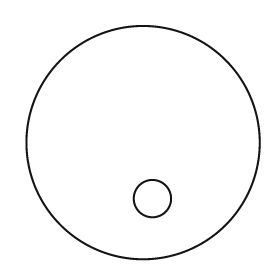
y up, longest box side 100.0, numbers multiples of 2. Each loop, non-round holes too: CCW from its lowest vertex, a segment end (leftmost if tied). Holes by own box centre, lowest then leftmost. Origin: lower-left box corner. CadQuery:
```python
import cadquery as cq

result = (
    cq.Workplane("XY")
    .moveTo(50.0, 50.0)
    .circle(50.0)
    .moveTo(54.0, 26.0)
    .circle(8.0)
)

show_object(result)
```